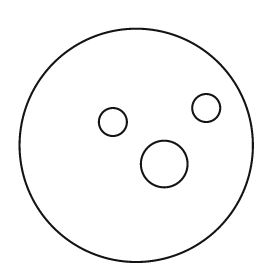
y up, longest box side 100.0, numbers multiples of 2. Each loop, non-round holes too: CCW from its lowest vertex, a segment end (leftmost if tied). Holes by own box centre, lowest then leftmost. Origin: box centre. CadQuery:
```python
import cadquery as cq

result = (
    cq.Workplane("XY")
    .moveTo(0.0, 0.0)
    .circle(50.0)
    .moveTo(12.0, -8.0)
    .circle(10.0)
    .moveTo(-10.0, 10.0)
    .circle(6.0)
    .moveTo(30.0, 16.0)
    .circle(6.0)
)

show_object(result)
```